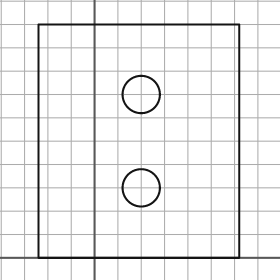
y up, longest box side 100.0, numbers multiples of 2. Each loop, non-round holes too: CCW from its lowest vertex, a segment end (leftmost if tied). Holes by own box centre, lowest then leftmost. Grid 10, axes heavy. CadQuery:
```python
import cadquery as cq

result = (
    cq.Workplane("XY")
    .moveTo(-24.0, 0.0)
    .lineTo(62.0, 0.0)
    .lineTo(62.0, 100.0)
    .lineTo(-24.0, 100.0)
    .close()
    .moveTo(20.0, 30.0)
    .circle(8.0)
    .moveTo(20.0, 70.0)
    .circle(8.0)
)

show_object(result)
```